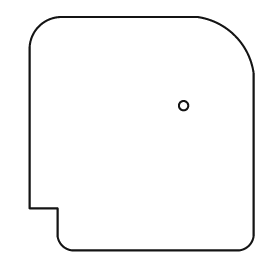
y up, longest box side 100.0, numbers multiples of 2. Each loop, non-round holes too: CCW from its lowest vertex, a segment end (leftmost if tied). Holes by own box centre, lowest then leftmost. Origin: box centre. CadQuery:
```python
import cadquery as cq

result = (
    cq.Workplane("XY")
    .moveTo(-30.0, -50.0)
    .lineTo(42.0, -50.0)
    .threePointArc((46.0, -48.0), (48.0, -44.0))
    .lineTo(48.0, 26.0)
    .threePointArc((40.0, 42.0), (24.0, 50.0))
    .lineTo(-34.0, 50.0)
    .threePointArc((-44.0, 46.0), (-48.0, 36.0))
    .lineTo(-48.0, -32.0)
    .lineTo(-36.0, -32.0)
    .lineTo(-36.0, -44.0)
    .threePointArc((-34.0, -48.0), (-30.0, -50.0))
    .close()
    .moveTo(18.0, 12.0)
    .circle(2.0)
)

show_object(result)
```